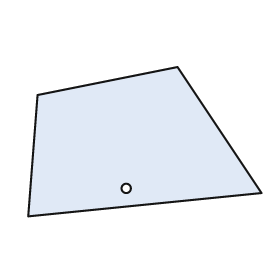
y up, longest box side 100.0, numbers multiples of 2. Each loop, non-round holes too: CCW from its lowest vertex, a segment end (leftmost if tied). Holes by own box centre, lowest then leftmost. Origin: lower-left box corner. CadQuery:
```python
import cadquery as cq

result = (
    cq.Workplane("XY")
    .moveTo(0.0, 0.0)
    .lineTo(100.0, 10.0)
    .lineTo(64.0, 64.0)
    .lineTo(4.0, 52.0)
    .close()
    .moveTo(42.0, 12.0)
    .circle(2.0)
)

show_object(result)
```